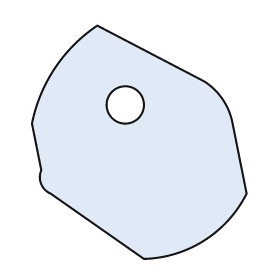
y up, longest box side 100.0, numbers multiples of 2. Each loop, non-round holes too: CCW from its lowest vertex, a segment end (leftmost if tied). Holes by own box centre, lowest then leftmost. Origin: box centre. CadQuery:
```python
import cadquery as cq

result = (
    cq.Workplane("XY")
    .moveTo(2.0, -50.0)
    .threePointArc((28.0, -42.0), (46.0, -22.0))
    .lineTo(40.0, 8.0)
    .threePointArc((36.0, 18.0), (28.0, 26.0))
    .lineTo(-18.0, 50.0)
    .threePointArc((-36.0, 32.0), (-46.0, 8.0))
    .lineTo(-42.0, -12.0)
    .threePointArc((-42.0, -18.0), (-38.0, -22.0))
    .close()
    .moveTo(-6.0, 16.0)
    .circle(8.0)
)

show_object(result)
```